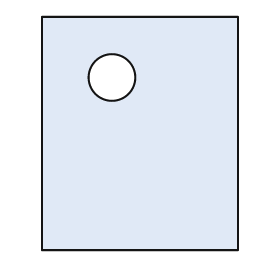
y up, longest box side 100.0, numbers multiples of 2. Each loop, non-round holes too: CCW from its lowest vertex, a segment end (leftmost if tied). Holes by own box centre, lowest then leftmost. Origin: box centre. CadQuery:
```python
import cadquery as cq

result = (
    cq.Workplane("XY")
    .moveTo(-42.0, -50.0)
    .lineTo(42.0, -50.0)
    .lineTo(42.0, 50.0)
    .lineTo(-42.0, 50.0)
    .close()
    .moveTo(-12.0, 24.0)
    .circle(10.0)
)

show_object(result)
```